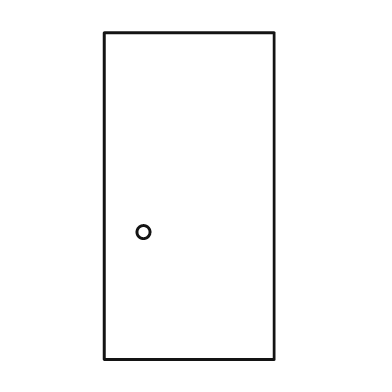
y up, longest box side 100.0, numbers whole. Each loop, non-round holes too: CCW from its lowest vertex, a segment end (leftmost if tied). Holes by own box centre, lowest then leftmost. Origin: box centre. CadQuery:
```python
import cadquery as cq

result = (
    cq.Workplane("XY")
    .moveTo(-26.0, -50.0)
    .lineTo(26.0, -50.0)
    .lineTo(26.0, 50.0)
    .lineTo(-26.0, 50.0)
    .close()
    .moveTo(-14.0, -11.0)
    .circle(2.0)
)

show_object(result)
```